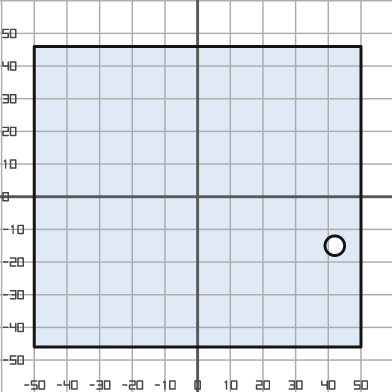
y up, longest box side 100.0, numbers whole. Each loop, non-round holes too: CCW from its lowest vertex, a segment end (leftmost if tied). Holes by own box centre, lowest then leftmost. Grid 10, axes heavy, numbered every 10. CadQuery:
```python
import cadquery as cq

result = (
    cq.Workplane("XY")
    .moveTo(-50.0, -46.0)
    .lineTo(50.0, -46.0)
    .lineTo(50.0, 46.0)
    .lineTo(-50.0, 46.0)
    .close()
    .moveTo(42.0, -15.0)
    .circle(3.0)
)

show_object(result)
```